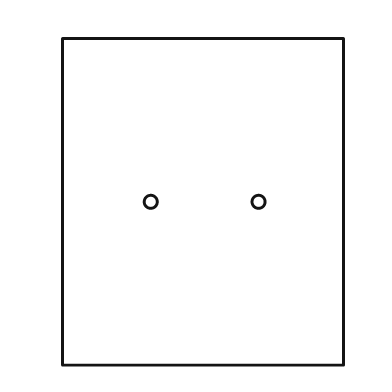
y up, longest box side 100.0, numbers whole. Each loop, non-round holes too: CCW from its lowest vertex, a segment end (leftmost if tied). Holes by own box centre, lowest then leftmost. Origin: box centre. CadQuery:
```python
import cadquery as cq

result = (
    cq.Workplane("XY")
    .moveTo(-43.0, -50.0)
    .lineTo(43.0, -50.0)
    .lineTo(43.0, 50.0)
    .lineTo(-43.0, 50.0)
    .close()
    .moveTo(-16.0, 0.0)
    .circle(2.0)
    .moveTo(17.0, 0.0)
    .circle(2.0)
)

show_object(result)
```